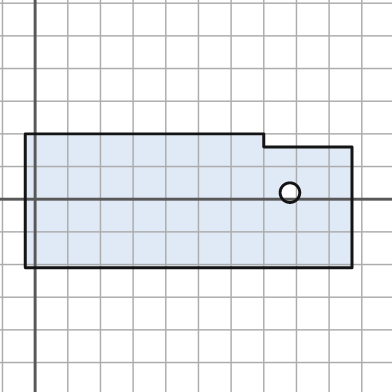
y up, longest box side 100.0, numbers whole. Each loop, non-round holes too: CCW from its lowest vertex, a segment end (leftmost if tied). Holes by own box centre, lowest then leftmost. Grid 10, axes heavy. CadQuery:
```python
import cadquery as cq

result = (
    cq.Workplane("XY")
    .moveTo(-3.0, -21.0)
    .lineTo(97.0, -21.0)
    .lineTo(97.0, 16.0)
    .lineTo(70.0, 16.0)
    .lineTo(70.0, 20.0)
    .lineTo(-3.0, 20.0)
    .close()
    .moveTo(78.0, 2.0)
    .circle(3.0)
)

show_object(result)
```